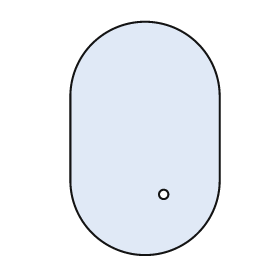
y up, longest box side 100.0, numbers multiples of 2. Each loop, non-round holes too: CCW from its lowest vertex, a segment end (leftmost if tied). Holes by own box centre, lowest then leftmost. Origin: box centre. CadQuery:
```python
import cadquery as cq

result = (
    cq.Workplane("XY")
    .moveTo(-32.0, -18.0)
    .threePointArc((0.0, -50.0), (32.0, -18.0))
    .lineTo(32.0, 18.0)
    .threePointArc((0.0, 50.0), (-32.0, 18.0))
    .close()
    .moveTo(8.0, -24.0)
    .circle(2.0)
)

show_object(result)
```